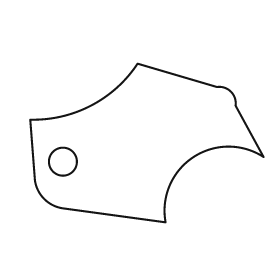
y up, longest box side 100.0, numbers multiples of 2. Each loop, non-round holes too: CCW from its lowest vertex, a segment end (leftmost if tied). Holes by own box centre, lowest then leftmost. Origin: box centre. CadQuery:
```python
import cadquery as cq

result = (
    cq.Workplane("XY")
    .moveTo(8.0, -34.0)
    .threePointArc((20.0, -6.0), (50.0, -6.0))
    .lineTo(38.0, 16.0)
    .threePointArc((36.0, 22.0), (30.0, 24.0))
    .lineTo(-4.0, 34.0)
    .threePointArc((-24.0, 16.0), (-50.0, 10.0))
    .lineTo(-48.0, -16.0)
    .threePointArc((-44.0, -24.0), (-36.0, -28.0))
    .close()
    .moveTo(-36.0, -8.0)
    .circle(6.0)
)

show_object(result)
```